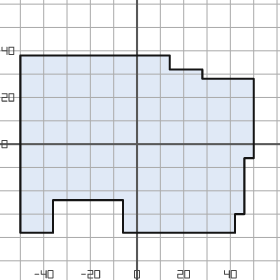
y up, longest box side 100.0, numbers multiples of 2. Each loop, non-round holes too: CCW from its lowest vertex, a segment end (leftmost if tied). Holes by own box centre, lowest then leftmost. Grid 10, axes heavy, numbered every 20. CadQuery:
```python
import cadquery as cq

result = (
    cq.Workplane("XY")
    .moveTo(-50.0, -38.0)
    .lineTo(-36.0, -38.0)
    .lineTo(-36.0, -24.0)
    .lineTo(-6.0, -24.0)
    .lineTo(-6.0, -38.0)
    .lineTo(42.0, -38.0)
    .lineTo(42.0, -30.0)
    .lineTo(46.0, -30.0)
    .lineTo(46.0, -6.0)
    .lineTo(50.0, -6.0)
    .lineTo(50.0, 28.0)
    .lineTo(28.0, 28.0)
    .lineTo(28.0, 32.0)
    .lineTo(14.0, 32.0)
    .lineTo(14.0, 38.0)
    .lineTo(-50.0, 38.0)
    .close()
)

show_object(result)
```